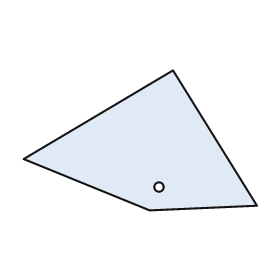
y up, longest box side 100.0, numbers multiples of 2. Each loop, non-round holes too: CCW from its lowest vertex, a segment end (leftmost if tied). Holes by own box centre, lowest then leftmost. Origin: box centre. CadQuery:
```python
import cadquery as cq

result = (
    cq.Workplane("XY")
    .moveTo(4.0, -30.0)
    .lineTo(50.0, -28.0)
    .lineTo(14.0, 30.0)
    .lineTo(-50.0, -8.0)
    .close()
    .moveTo(8.0, -20.0)
    .circle(2.0)
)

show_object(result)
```